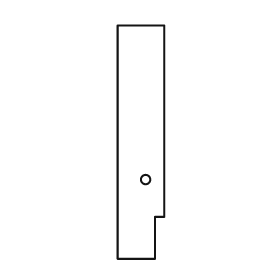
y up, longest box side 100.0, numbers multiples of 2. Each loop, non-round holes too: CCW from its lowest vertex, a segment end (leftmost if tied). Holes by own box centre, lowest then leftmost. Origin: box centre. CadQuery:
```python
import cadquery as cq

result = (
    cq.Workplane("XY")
    .moveTo(-10.0, -50.0)
    .lineTo(6.0, -50.0)
    .lineTo(6.0, -32.0)
    .lineTo(10.0, -32.0)
    .lineTo(10.0, 50.0)
    .lineTo(-10.0, 50.0)
    .close()
    .moveTo(2.0, -16.0)
    .circle(2.0)
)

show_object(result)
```